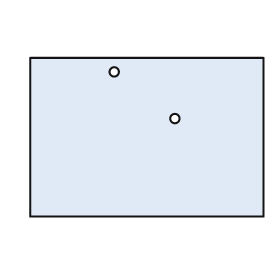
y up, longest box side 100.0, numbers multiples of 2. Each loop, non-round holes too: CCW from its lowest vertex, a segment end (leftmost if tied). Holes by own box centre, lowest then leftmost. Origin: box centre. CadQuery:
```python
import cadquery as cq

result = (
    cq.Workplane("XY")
    .moveTo(-50.0, -34.0)
    .lineTo(50.0, -34.0)
    .lineTo(50.0, 34.0)
    .lineTo(-50.0, 34.0)
    .close()
    .moveTo(12.0, 8.0)
    .circle(2.0)
    .moveTo(-14.0, 28.0)
    .circle(2.0)
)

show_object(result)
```